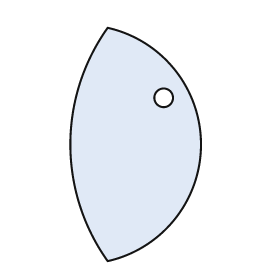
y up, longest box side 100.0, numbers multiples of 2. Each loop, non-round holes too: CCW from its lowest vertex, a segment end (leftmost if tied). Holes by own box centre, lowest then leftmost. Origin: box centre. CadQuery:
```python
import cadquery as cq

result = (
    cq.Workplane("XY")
    .moveTo(-12.0, -50.0)
    .threePointArc((28.0, 0.0), (-12.0, 50.0))
    .threePointArc((-28.0, 0.0), (-12.0, -50.0))
    .close()
    .moveTo(12.0, 20.0)
    .circle(4.0)
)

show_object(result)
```